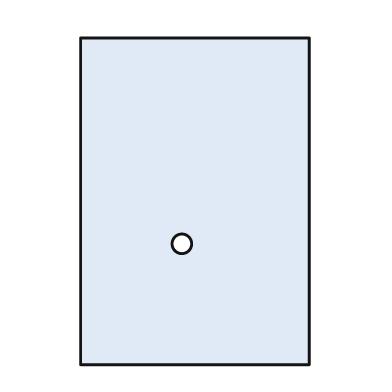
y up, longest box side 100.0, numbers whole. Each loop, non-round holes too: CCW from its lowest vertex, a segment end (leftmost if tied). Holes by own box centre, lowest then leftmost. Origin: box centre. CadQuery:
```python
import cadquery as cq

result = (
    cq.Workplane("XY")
    .moveTo(-35.0, -50.0)
    .lineTo(35.0, -50.0)
    .lineTo(35.0, 50.0)
    .lineTo(-35.0, 50.0)
    .close()
    .moveTo(-4.0, -13.0)
    .circle(3.0)
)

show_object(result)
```